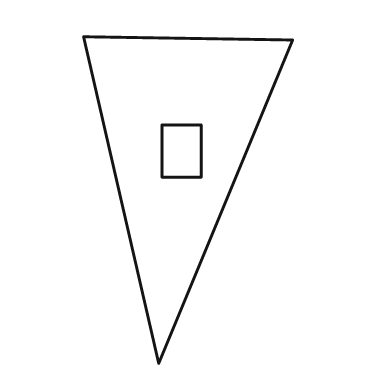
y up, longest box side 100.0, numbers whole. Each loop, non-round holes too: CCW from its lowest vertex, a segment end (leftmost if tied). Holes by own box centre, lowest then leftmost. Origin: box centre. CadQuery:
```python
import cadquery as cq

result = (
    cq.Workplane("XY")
    .moveTo(-9.0, -50.0)
    .lineTo(32.0, 49.0)
    .lineTo(-32.0, 50.0)
    .close()
    .moveTo(-8.0, 7.0)
    .lineTo(4.0, 7.0)
    .lineTo(4.0, 23.0)
    .lineTo(-8.0, 23.0)
    .close()
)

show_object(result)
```